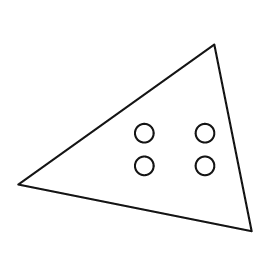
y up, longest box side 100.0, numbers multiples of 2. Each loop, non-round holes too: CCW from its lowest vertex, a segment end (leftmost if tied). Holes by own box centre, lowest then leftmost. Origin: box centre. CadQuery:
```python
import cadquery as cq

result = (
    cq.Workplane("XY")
    .moveTo(50.0, -40.0)
    .lineTo(34.0, 40.0)
    .lineTo(-50.0, -20.0)
    .close()
    .moveTo(4.0, -12.0)
    .circle(4.0)
    .moveTo(30.0, -12.0)
    .circle(4.0)
    .moveTo(4.0, 2.0)
    .circle(4.0)
    .moveTo(30.0, 2.0)
    .circle(4.0)
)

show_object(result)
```